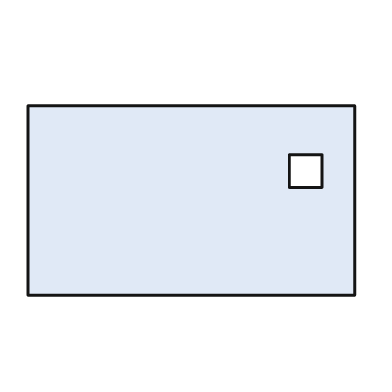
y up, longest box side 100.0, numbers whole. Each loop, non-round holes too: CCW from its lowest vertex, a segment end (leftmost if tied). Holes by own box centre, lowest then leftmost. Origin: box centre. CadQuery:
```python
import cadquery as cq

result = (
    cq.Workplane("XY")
    .moveTo(-50.0, -29.0)
    .lineTo(50.0, -29.0)
    .lineTo(50.0, 29.0)
    .lineTo(-50.0, 29.0)
    .close()
    .moveTo(30.0, 4.0)
    .lineTo(40.0, 4.0)
    .lineTo(40.0, 14.0)
    .lineTo(30.0, 14.0)
    .close()
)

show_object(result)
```